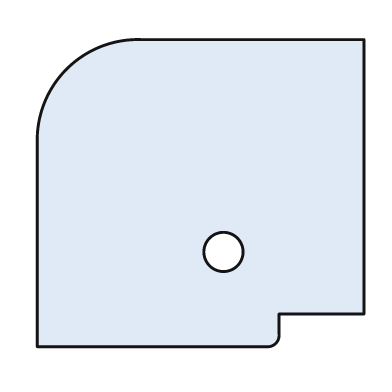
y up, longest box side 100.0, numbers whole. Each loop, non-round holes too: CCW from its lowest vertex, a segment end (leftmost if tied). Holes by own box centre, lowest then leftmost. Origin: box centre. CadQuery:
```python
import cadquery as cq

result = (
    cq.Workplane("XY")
    .moveTo(-50.0, -47.0)
    .lineTo(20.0, -47.0)
    .threePointArc((23.0, -46.0), (24.0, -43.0))
    .lineTo(24.0, -37.0)
    .lineTo(50.0, -37.0)
    .lineTo(50.0, 47.0)
    .lineTo(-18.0, 47.0)
    .threePointArc((-41.0, 38.0), (-50.0, 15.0))
    .close()
    .moveTo(7.0, -18.0)
    .circle(6.0)
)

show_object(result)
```